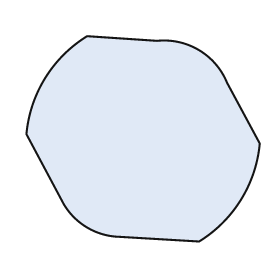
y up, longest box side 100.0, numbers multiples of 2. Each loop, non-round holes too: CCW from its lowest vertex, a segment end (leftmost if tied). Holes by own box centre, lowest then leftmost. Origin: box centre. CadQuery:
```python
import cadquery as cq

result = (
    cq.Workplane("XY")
    .moveTo(24.0, -44.0)
    .threePointArc((42.0, -26.0), (50.0, -2.0))
    .lineTo(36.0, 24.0)
    .threePointArc((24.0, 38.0), (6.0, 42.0))
    .lineTo(-24.0, 44.0)
    .threePointArc((-42.0, 26.0), (-50.0, 2.0))
    .lineTo(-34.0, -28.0)
    .threePointArc((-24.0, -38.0), (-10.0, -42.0))
    .close()
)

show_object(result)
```